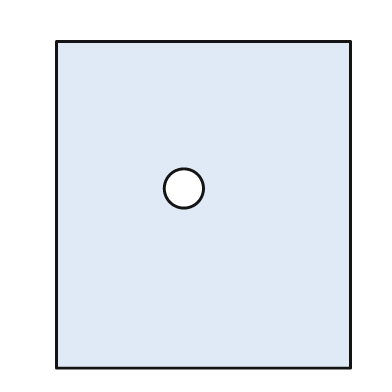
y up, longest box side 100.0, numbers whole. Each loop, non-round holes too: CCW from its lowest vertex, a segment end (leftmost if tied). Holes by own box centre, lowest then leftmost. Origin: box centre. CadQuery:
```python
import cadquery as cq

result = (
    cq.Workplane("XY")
    .moveTo(-45.0, -50.0)
    .lineTo(45.0, -50.0)
    .lineTo(45.0, 50.0)
    .lineTo(-45.0, 50.0)
    .close()
    .moveTo(-6.0, 5.0)
    .circle(6.0)
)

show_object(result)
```